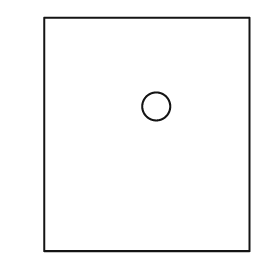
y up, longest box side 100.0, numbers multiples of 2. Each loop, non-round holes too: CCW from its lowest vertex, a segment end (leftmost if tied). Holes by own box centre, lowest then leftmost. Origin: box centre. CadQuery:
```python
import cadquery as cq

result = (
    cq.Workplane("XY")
    .moveTo(-44.0, -50.0)
    .lineTo(44.0, -50.0)
    .lineTo(44.0, 50.0)
    .lineTo(-44.0, 50.0)
    .close()
    .moveTo(4.0, 12.0)
    .circle(6.0)
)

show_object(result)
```